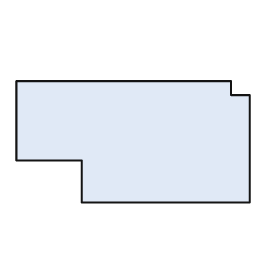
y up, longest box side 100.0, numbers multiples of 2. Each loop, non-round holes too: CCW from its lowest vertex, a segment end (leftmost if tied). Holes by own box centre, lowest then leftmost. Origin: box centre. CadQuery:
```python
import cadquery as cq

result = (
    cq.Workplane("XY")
    .moveTo(-22.0, -26.0)
    .lineTo(50.0, -26.0)
    .lineTo(50.0, 20.0)
    .lineTo(42.0, 20.0)
    .lineTo(42.0, 26.0)
    .lineTo(-50.0, 26.0)
    .lineTo(-50.0, -8.0)
    .lineTo(-22.0, -8.0)
    .close()
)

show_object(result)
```